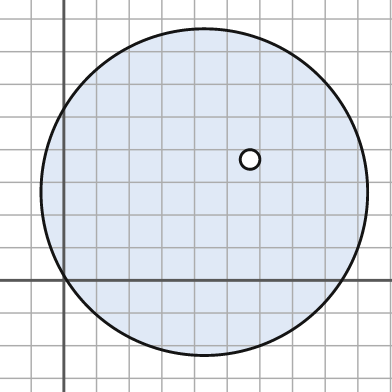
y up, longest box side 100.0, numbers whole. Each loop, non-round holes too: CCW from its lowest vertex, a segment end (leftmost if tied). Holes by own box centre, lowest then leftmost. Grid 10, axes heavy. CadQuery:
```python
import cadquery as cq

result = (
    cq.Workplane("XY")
    .moveTo(43.0, 27.0)
    .circle(50.0)
    .moveTo(57.0, 37.0)
    .circle(3.0)
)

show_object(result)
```